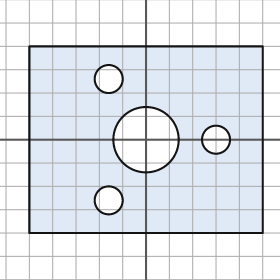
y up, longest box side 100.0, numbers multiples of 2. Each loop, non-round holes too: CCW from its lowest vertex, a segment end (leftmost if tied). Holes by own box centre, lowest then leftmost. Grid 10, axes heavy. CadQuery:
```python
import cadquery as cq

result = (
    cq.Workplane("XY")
    .moveTo(-50.0, -40.0)
    .lineTo(50.0, -40.0)
    .lineTo(50.0, 40.0)
    .lineTo(-50.0, 40.0)
    .close()
    .moveTo(-16.0, -26.0)
    .circle(6.0)
    .moveTo(0.0, 0.0)
    .circle(14.0)
    .moveTo(30.0, 0.0)
    .circle(6.0)
    .moveTo(-16.0, 26.0)
    .circle(6.0)
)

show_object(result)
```